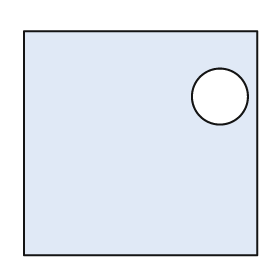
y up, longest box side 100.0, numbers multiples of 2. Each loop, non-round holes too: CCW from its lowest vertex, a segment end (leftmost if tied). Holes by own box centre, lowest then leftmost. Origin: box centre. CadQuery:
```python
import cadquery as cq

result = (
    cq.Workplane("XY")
    .moveTo(-50.0, -48.0)
    .lineTo(50.0, -48.0)
    .lineTo(50.0, 48.0)
    .lineTo(-50.0, 48.0)
    .close()
    .moveTo(34.0, 20.0)
    .circle(12.0)
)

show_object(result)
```